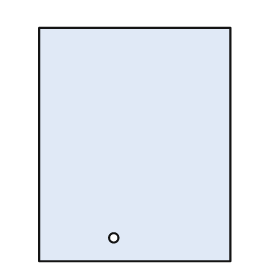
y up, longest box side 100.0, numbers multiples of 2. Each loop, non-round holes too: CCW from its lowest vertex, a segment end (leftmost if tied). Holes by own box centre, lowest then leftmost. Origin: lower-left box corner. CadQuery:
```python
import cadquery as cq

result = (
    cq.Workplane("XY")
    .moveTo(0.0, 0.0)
    .lineTo(82.0, 0.0)
    .lineTo(82.0, 100.0)
    .lineTo(0.0, 100.0)
    .close()
    .moveTo(32.0, 10.0)
    .circle(2.0)
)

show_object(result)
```